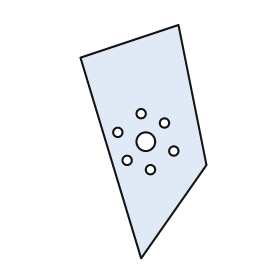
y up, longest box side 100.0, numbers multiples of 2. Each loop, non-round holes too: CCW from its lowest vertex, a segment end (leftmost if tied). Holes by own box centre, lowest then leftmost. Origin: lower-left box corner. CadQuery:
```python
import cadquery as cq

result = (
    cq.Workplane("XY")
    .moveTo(26.0, 0.0)
    .lineTo(54.0, 40.0)
    .lineTo(42.0, 100.0)
    .lineTo(0.0, 86.0)
    .close()
    .moveTo(30.0, 38.0)
    .circle(2.0)
    .moveTo(20.0, 42.0)
    .circle(2.0)
    .moveTo(40.0, 46.0)
    .circle(2.0)
    .moveTo(28.0, 50.0)
    .circle(4.0)
    .moveTo(16.0, 54.0)
    .circle(2.0)
    .moveTo(36.0, 58.0)
    .circle(2.0)
    .moveTo(26.0, 62.0)
    .circle(2.0)
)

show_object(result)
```